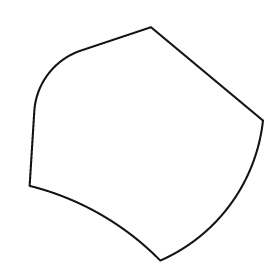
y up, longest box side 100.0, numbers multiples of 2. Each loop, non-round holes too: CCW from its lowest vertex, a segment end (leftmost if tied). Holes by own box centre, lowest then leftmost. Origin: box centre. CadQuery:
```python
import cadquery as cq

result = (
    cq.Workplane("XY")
    .moveTo(6.0, -50.0)
    .threePointArc((36.0, -26.0), (50.0, 10.0))
    .lineTo(2.0, 50.0)
    .lineTo(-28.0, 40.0)
    .threePointArc((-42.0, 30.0), (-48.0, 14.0))
    .lineTo(-50.0, -18.0)
    .threePointArc((-20.0, -30.0), (6.0, -50.0))
    .close()
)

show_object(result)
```